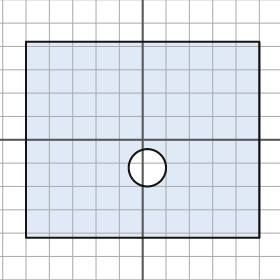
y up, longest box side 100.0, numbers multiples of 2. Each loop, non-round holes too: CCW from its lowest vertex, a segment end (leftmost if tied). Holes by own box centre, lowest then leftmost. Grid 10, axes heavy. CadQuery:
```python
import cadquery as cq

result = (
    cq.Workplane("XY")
    .moveTo(-50.0, -42.0)
    .lineTo(50.0, -42.0)
    .lineTo(50.0, 42.0)
    .lineTo(-50.0, 42.0)
    .close()
    .moveTo(2.0, -12.0)
    .circle(8.0)
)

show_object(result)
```